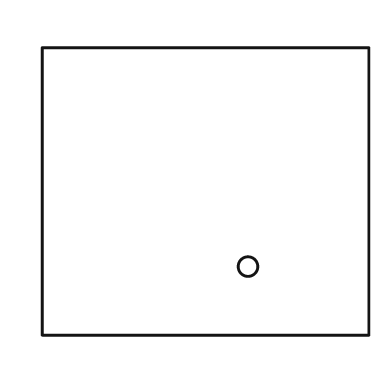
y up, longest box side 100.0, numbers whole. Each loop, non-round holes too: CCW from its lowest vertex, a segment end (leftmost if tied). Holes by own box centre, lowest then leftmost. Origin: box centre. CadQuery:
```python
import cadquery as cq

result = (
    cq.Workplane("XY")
    .moveTo(-50.0, -44.0)
    .lineTo(50.0, -44.0)
    .lineTo(50.0, 44.0)
    .lineTo(-50.0, 44.0)
    .close()
    .moveTo(13.0, -23.0)
    .circle(3.0)
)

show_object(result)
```